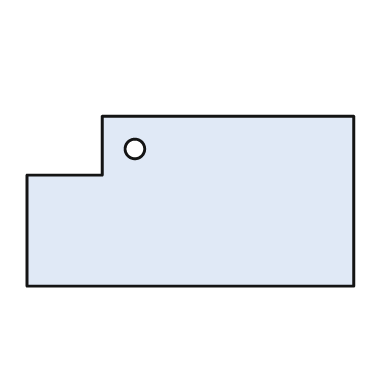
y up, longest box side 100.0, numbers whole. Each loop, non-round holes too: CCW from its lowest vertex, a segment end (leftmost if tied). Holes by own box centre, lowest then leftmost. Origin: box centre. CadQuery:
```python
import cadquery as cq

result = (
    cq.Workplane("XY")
    .moveTo(-50.0, -26.0)
    .lineTo(50.0, -26.0)
    .lineTo(50.0, 26.0)
    .lineTo(-27.0, 26.0)
    .lineTo(-27.0, 8.0)
    .lineTo(-50.0, 8.0)
    .close()
    .moveTo(-17.0, 16.0)
    .circle(3.0)
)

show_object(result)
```